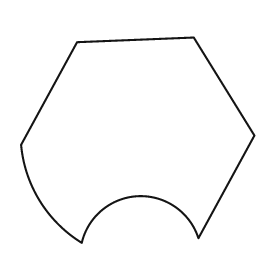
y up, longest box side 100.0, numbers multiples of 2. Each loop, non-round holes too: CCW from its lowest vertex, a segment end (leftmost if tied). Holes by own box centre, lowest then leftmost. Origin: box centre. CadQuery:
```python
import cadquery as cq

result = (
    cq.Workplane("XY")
    .moveTo(-24.0, -44.0)
    .threePointArc((0.0, -24.0), (26.0, -42.0))
    .lineTo(50.0, 2.0)
    .lineTo(24.0, 44.0)
    .lineTo(-26.0, 42.0)
    .lineTo(-50.0, -2.0)
    .threePointArc((-42.0, -26.0), (-24.0, -44.0))
    .close()
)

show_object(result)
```